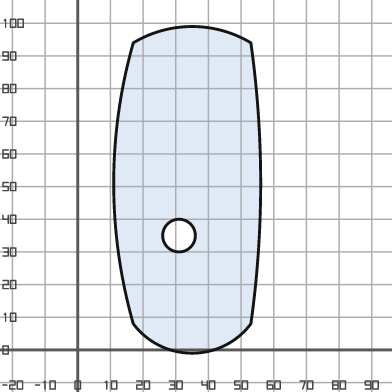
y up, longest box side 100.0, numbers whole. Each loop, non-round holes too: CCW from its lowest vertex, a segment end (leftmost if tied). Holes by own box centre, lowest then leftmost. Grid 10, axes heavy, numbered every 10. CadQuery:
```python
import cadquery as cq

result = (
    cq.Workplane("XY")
    .moveTo(17.0, 8.0)
    .threePointArc((35.0, -1.0), (53.0, 8.0))
    .threePointArc((56.0, 51.0), (53.0, 94.0))
    .threePointArc((35.0, 99.0), (17.0, 94.0))
    .threePointArc((11.0, 51.0), (17.0, 8.0))
    .close()
    .moveTo(31.0, 35.0)
    .circle(5.0)
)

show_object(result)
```